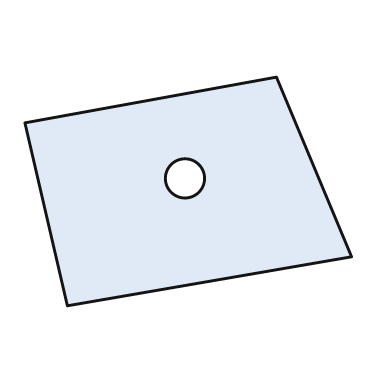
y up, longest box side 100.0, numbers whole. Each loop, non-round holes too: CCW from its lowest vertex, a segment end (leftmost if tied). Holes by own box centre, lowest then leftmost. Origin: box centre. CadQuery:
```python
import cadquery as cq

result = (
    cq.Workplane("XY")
    .moveTo(-37.0, -35.0)
    .lineTo(50.0, -20.0)
    .lineTo(27.0, 35.0)
    .lineTo(-50.0, 21.0)
    .close()
    .moveTo(-1.0, 4.0)
    .circle(6.0)
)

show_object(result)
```